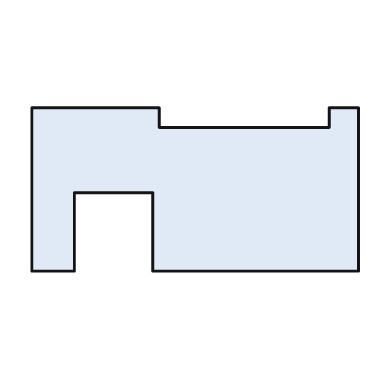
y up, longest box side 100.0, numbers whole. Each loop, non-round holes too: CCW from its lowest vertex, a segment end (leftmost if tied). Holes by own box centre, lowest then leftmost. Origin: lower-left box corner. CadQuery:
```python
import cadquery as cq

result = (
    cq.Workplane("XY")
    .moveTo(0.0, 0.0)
    .lineTo(13.0, 0.0)
    .lineTo(13.0, 24.0)
    .lineTo(37.0, 24.0)
    .lineTo(37.0, 0.0)
    .lineTo(100.0, 0.0)
    .lineTo(100.0, 50.0)
    .lineTo(91.0, 50.0)
    .lineTo(91.0, 44.0)
    .lineTo(39.0, 44.0)
    .lineTo(39.0, 50.0)
    .lineTo(0.0, 50.0)
    .close()
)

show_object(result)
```